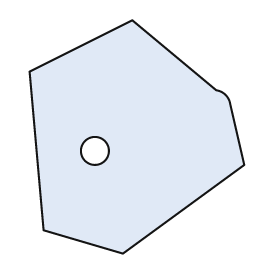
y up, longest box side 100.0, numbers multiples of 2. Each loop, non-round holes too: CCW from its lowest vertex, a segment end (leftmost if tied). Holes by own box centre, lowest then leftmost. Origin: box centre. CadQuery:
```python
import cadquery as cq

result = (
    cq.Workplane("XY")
    .moveTo(-6.0, -50.0)
    .lineTo(46.0, -12.0)
    .lineTo(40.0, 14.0)
    .threePointArc((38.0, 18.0), (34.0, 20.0))
    .lineTo(-2.0, 50.0)
    .lineTo(-46.0, 28.0)
    .lineTo(-40.0, -40.0)
    .close()
    .moveTo(-18.0, -6.0)
    .circle(6.0)
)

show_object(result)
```